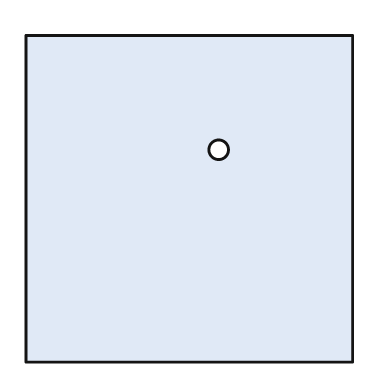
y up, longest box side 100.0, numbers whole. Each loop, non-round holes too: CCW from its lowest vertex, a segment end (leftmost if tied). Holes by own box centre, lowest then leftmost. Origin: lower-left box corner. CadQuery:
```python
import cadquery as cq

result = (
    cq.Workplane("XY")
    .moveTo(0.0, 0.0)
    .lineTo(100.0, 0.0)
    .lineTo(100.0, 100.0)
    .lineTo(0.0, 100.0)
    .close()
    .moveTo(59.0, 65.0)
    .circle(3.0)
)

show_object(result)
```